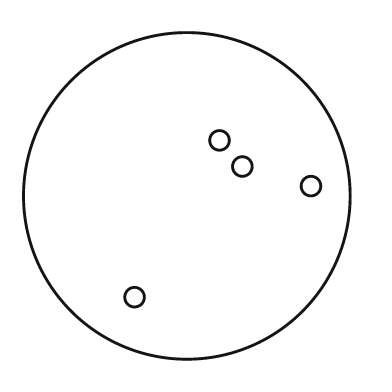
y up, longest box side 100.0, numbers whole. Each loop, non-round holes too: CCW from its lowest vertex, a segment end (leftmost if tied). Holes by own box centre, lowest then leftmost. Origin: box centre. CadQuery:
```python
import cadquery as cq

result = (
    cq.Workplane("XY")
    .moveTo(0.0, 0.0)
    .circle(50.0)
    .moveTo(-16.0, -31.0)
    .circle(3.0)
    .moveTo(38.0, 3.0)
    .circle(3.0)
    .moveTo(17.0, 9.0)
    .circle(3.0)
    .moveTo(10.0, 17.0)
    .circle(3.0)
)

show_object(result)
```